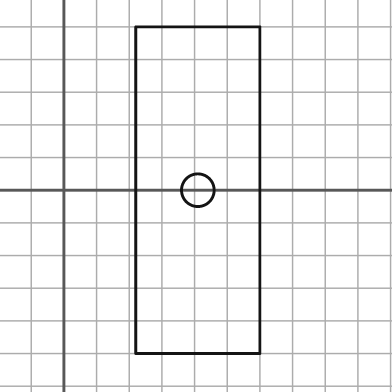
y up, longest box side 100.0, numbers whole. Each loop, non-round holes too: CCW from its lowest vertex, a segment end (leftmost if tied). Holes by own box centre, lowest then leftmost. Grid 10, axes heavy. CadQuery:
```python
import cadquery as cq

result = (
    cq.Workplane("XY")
    .moveTo(22.0, -50.0)
    .lineTo(60.0, -50.0)
    .lineTo(60.0, 50.0)
    .lineTo(22.0, 50.0)
    .close()
    .moveTo(41.0, 0.0)
    .circle(5.0)
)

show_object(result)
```